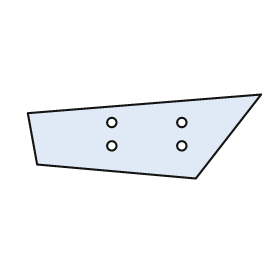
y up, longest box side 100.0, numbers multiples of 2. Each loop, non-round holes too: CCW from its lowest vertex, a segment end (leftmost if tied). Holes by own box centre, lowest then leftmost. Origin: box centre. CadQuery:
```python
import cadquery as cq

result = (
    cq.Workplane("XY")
    .moveTo(22.0, -18.0)
    .lineTo(50.0, 18.0)
    .lineTo(-50.0, 10.0)
    .lineTo(-46.0, -12.0)
    .close()
    .moveTo(-14.0, -4.0)
    .circle(2.0)
    .moveTo(16.0, -4.0)
    .circle(2.0)
    .moveTo(-14.0, 6.0)
    .circle(2.0)
    .moveTo(16.0, 6.0)
    .circle(2.0)
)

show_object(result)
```